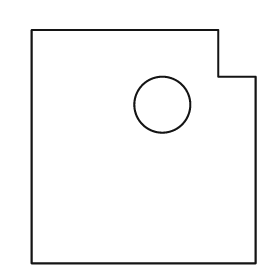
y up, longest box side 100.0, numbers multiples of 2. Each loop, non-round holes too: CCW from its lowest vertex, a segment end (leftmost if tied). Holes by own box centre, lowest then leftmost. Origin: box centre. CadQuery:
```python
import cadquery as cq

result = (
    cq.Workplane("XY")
    .moveTo(-48.0, -50.0)
    .lineTo(48.0, -50.0)
    .lineTo(48.0, 30.0)
    .lineTo(32.0, 30.0)
    .lineTo(32.0, 50.0)
    .lineTo(-48.0, 50.0)
    .close()
    .moveTo(8.0, 18.0)
    .circle(12.0)
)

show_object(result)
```